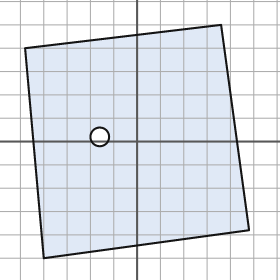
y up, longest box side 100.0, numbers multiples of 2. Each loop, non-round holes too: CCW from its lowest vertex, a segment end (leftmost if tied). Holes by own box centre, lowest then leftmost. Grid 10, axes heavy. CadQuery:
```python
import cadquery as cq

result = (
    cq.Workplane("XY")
    .moveTo(-40.0, -50.0)
    .lineTo(48.0, -38.0)
    .lineTo(36.0, 50.0)
    .lineTo(-48.0, 40.0)
    .close()
    .moveTo(-16.0, 2.0)
    .circle(4.0)
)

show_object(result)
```